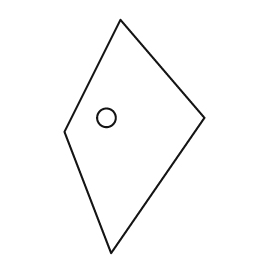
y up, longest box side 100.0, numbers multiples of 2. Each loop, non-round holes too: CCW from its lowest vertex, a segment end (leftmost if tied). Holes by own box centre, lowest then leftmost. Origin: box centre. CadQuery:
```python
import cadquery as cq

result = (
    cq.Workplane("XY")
    .moveTo(-10.0, -50.0)
    .lineTo(30.0, 8.0)
    .lineTo(-6.0, 50.0)
    .lineTo(-30.0, 2.0)
    .close()
    .moveTo(-12.0, 8.0)
    .circle(4.0)
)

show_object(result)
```